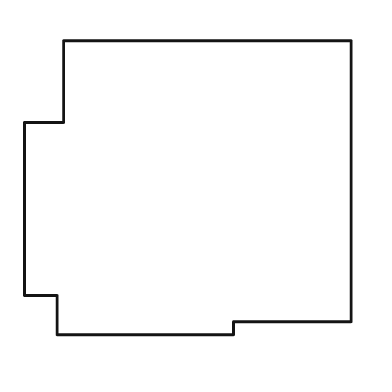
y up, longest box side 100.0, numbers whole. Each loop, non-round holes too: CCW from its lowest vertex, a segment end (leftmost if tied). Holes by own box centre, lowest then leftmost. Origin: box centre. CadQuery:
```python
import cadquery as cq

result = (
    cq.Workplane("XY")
    .moveTo(-40.0, -45.0)
    .lineTo(14.0, -45.0)
    .lineTo(14.0, -41.0)
    .lineTo(50.0, -41.0)
    .lineTo(50.0, 45.0)
    .lineTo(-38.0, 45.0)
    .lineTo(-38.0, 20.0)
    .lineTo(-50.0, 20.0)
    .lineTo(-50.0, -33.0)
    .lineTo(-40.0, -33.0)
    .close()
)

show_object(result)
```